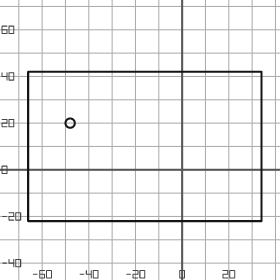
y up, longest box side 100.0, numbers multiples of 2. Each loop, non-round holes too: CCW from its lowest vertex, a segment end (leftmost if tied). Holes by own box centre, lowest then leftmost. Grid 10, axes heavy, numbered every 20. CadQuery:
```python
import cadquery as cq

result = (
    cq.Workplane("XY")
    .moveTo(-66.0, -22.0)
    .lineTo(34.0, -22.0)
    .lineTo(34.0, 42.0)
    .lineTo(-66.0, 42.0)
    .close()
    .moveTo(-48.0, 20.0)
    .circle(2.0)
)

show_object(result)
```